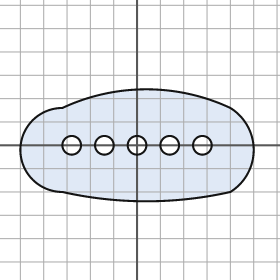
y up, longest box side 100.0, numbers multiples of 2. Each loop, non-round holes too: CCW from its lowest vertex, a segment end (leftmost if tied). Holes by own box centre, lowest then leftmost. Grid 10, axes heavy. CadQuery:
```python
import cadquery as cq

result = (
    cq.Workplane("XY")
    .moveTo(-32.0, -20.0)
    .threePointArc((4.0, -24.0), (40.0, -20.0))
    .threePointArc((50.0, -2.0), (40.0, 16.0))
    .threePointArc((4.0, 24.0), (-32.0, 16.0))
    .threePointArc((-50.0, -2.0), (-32.0, -20.0))
    .close()
    .moveTo(-28.0, 0.0)
    .circle(4.0)
    .moveTo(-14.0, 0.0)
    .circle(4.0)
    .moveTo(0.0, 0.0)
    .circle(4.0)
    .moveTo(14.0, 0.0)
    .circle(4.0)
    .moveTo(28.0, 0.0)
    .circle(4.0)
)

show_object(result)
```